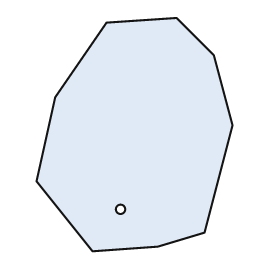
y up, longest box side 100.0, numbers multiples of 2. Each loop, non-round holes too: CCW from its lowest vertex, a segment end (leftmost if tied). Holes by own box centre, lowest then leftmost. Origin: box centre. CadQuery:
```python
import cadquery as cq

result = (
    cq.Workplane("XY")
    .moveTo(-18.0, -50.0)
    .lineTo(10.0, -48.0)
    .lineTo(30.0, -42.0)
    .lineTo(42.0, 4.0)
    .lineTo(34.0, 34.0)
    .lineTo(18.0, 50.0)
    .lineTo(-12.0, 48.0)
    .lineTo(-34.0, 16.0)
    .lineTo(-42.0, -20.0)
    .close()
    .moveTo(-6.0, -32.0)
    .circle(2.0)
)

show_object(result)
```